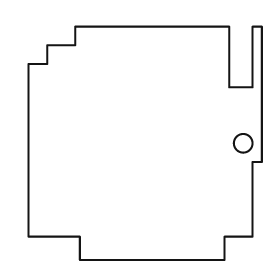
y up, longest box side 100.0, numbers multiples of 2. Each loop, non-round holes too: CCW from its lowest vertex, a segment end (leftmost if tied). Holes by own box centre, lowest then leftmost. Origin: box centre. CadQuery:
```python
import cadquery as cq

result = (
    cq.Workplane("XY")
    .moveTo(-28.0, -50.0)
    .lineTo(34.0, -50.0)
    .lineTo(34.0, -40.0)
    .lineTo(46.0, -40.0)
    .lineTo(46.0, -8.0)
    .lineTo(50.0, -8.0)
    .lineTo(50.0, 50.0)
    .lineTo(46.0, 50.0)
    .lineTo(46.0, 24.0)
    .lineTo(36.0, 24.0)
    .lineTo(36.0, 50.0)
    .lineTo(-30.0, 50.0)
    .lineTo(-30.0, 42.0)
    .lineTo(-42.0, 42.0)
    .lineTo(-42.0, 34.0)
    .lineTo(-50.0, 34.0)
    .lineTo(-50.0, -40.0)
    .lineTo(-28.0, -40.0)
    .close()
    .moveTo(42.0, 0.0)
    .circle(4.0)
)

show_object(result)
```